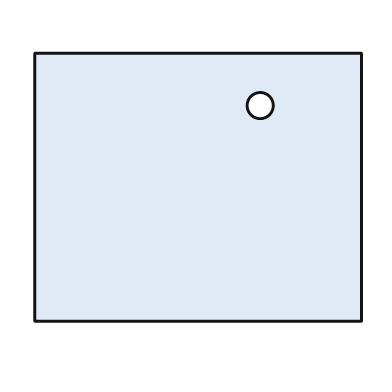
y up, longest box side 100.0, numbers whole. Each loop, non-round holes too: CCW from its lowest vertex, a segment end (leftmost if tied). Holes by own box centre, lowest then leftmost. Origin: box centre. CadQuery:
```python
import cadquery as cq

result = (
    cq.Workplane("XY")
    .moveTo(-50.0, -41.0)
    .lineTo(50.0, -41.0)
    .lineTo(50.0, 41.0)
    .lineTo(-50.0, 41.0)
    .close()
    .moveTo(19.0, 25.0)
    .circle(4.0)
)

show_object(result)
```